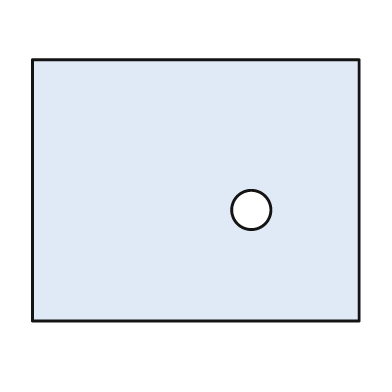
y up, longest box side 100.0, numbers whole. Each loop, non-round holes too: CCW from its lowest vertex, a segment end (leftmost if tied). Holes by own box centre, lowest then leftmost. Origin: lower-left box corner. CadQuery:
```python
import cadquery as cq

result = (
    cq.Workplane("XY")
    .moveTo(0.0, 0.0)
    .lineTo(100.0, 0.0)
    .lineTo(100.0, 80.0)
    .lineTo(0.0, 80.0)
    .close()
    .moveTo(67.0, 34.0)
    .circle(6.0)
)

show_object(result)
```